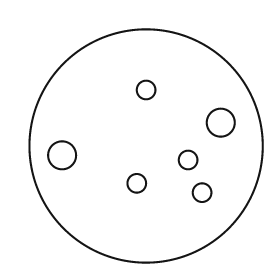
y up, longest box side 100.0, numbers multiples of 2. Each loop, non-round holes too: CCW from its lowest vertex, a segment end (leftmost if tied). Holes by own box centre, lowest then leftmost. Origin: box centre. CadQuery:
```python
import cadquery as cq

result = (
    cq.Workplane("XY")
    .moveTo(0.0, 0.0)
    .circle(50.0)
    .moveTo(24.0, -20.0)
    .circle(4.0)
    .moveTo(-4.0, -16.0)
    .circle(4.0)
    .moveTo(18.0, -6.0)
    .circle(4.0)
    .moveTo(-36.0, -4.0)
    .circle(6.0)
    .moveTo(32.0, 10.0)
    .circle(6.0)
    .moveTo(0.0, 24.0)
    .circle(4.0)
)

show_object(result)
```